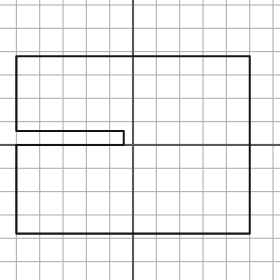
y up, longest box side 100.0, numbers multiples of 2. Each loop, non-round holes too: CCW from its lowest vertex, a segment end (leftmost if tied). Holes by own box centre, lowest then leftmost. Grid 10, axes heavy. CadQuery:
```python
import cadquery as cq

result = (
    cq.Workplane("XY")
    .moveTo(-50.0, -38.0)
    .lineTo(50.0, -38.0)
    .lineTo(50.0, 38.0)
    .lineTo(-50.0, 38.0)
    .lineTo(-50.0, 6.0)
    .lineTo(-4.0, 6.0)
    .lineTo(-4.0, 0.0)
    .lineTo(-50.0, 0.0)
    .close()
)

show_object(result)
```